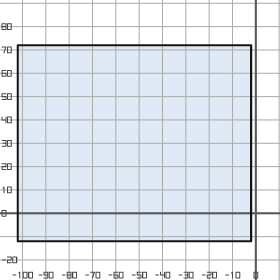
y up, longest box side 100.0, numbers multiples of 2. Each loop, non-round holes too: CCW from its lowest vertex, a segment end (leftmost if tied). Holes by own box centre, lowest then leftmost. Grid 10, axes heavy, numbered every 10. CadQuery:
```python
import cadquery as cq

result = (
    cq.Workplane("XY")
    .moveTo(-102.0, -12.0)
    .lineTo(-2.0, -12.0)
    .lineTo(-2.0, 72.0)
    .lineTo(-102.0, 72.0)
    .close()
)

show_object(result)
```